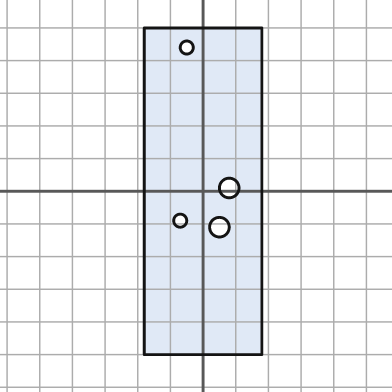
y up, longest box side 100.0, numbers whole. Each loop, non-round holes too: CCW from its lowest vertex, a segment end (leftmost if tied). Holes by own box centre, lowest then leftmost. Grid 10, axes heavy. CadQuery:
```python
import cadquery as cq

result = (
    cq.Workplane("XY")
    .moveTo(-18.0, -50.0)
    .lineTo(18.0, -50.0)
    .lineTo(18.0, 50.0)
    .lineTo(-18.0, 50.0)
    .close()
    .moveTo(5.0, -11.0)
    .circle(3.0)
    .moveTo(-7.0, -9.0)
    .circle(2.0)
    .moveTo(8.0, 1.0)
    .circle(3.0)
    .moveTo(-5.0, 44.0)
    .circle(2.0)
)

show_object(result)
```